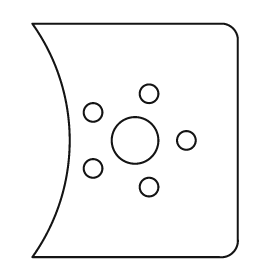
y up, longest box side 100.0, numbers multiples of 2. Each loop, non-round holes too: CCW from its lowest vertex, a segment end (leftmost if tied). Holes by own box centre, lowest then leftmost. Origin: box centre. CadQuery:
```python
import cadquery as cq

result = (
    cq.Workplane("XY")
    .moveTo(-44.0, -50.0)
    .lineTo(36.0, -50.0)
    .threePointArc((42.0, -48.0), (44.0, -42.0))
    .lineTo(44.0, 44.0)
    .threePointArc((42.0, 48.0), (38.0, 50.0))
    .lineTo(-44.0, 50.0)
    .threePointArc((-28.0, 0.0), (-44.0, -50.0))
    .close()
    .moveTo(6.0, -20.0)
    .circle(4.0)
    .moveTo(-18.0, -12.0)
    .circle(4.0)
    .moveTo(0.0, 0.0)
    .circle(10.0)
    .moveTo(22.0, 0.0)
    .circle(4.0)
    .moveTo(-18.0, 12.0)
    .circle(4.0)
    .moveTo(6.0, 20.0)
    .circle(4.0)
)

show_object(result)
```